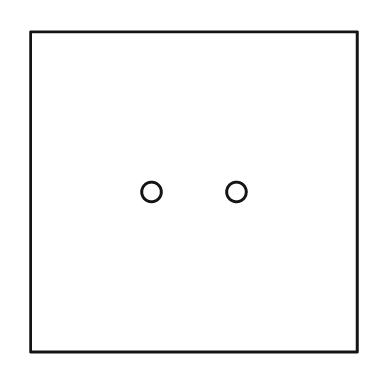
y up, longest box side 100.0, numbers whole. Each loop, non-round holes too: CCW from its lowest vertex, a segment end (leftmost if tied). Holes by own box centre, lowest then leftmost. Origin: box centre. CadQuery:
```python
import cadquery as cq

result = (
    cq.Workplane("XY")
    .moveTo(-50.0, -49.0)
    .lineTo(50.0, -49.0)
    .lineTo(50.0, 49.0)
    .lineTo(-50.0, 49.0)
    .close()
    .moveTo(-13.0, 0.0)
    .circle(3.0)
    .moveTo(13.0, 0.0)
    .circle(3.0)
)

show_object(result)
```